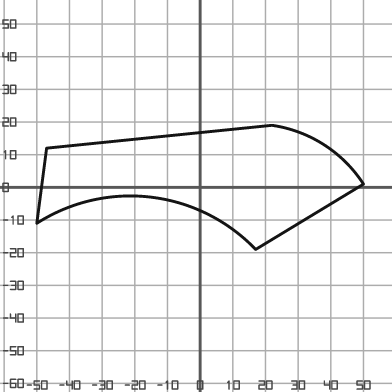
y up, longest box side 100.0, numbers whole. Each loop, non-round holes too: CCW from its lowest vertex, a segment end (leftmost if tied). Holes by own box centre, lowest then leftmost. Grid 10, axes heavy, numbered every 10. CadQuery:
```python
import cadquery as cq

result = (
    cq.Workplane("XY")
    .moveTo(17.0, -19.0)
    .lineTo(50.0, 1.0)
    .threePointArc((38.0, 13.0), (22.0, 19.0))
    .lineTo(-47.0, 12.0)
    .lineTo(-50.0, -11.0)
    .threePointArc((-15.0, -3.0), (17.0, -19.0))
    .close()
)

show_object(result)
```